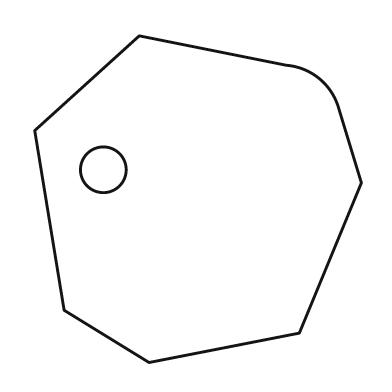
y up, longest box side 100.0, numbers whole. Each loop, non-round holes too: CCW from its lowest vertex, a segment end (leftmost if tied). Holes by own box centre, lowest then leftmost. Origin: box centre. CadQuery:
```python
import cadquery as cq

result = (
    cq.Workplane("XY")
    .moveTo(-15.0, -50.0)
    .lineTo(31.0, -41.0)
    .lineTo(50.0, 5.0)
    .lineTo(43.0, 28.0)
    .threePointArc((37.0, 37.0), (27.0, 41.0))
    .lineTo(-18.0, 50.0)
    .lineTo(-50.0, 21.0)
    .lineTo(-41.0, -34.0)
    .close()
    .moveTo(-29.0, 9.0)
    .circle(7.0)
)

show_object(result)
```